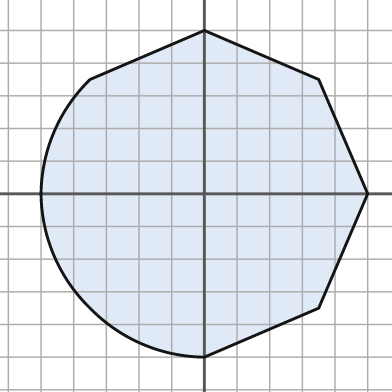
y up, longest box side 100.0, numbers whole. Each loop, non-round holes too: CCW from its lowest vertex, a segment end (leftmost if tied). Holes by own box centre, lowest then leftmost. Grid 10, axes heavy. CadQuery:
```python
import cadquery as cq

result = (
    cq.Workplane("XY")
    .moveTo(0.0, -50.0)
    .lineTo(35.0, -35.0)
    .lineTo(50.0, 0.0)
    .lineTo(35.0, 35.0)
    .lineTo(0.0, 50.0)
    .lineTo(-35.0, 35.0)
    .threePointArc((-46.0, 19.0), (-50.0, 0.0))
    .threePointArc((-46.0, -19.0), (-35.0, -35.0))
    .threePointArc((-19.0, -46.0), (0.0, -50.0))
    .close()
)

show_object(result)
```